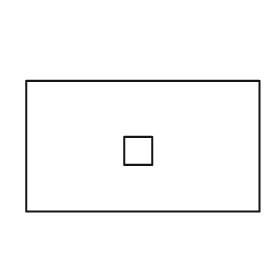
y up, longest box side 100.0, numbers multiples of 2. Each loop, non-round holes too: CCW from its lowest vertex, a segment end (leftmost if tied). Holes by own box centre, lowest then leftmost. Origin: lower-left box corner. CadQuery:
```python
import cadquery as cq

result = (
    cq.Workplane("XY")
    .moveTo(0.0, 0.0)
    .lineTo(100.0, 0.0)
    .lineTo(100.0, 56.0)
    .lineTo(0.0, 56.0)
    .close()
    .moveTo(42.0, 20.0)
    .lineTo(54.0, 20.0)
    .lineTo(54.0, 32.0)
    .lineTo(42.0, 32.0)
    .close()
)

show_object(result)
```